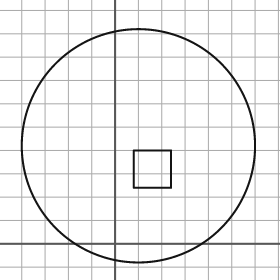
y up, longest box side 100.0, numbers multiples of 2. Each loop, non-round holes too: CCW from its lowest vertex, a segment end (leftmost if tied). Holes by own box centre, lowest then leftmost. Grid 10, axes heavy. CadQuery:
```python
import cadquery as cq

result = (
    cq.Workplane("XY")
    .moveTo(10.0, 42.0)
    .circle(50.0)
    .moveTo(8.0, 24.0)
    .lineTo(24.0, 24.0)
    .lineTo(24.0, 40.0)
    .lineTo(8.0, 40.0)
    .close()
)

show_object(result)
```